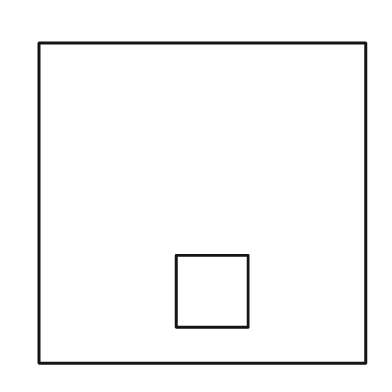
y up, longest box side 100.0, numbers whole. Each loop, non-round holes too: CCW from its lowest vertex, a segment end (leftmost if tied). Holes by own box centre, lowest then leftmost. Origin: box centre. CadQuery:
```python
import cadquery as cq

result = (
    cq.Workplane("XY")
    .moveTo(-50.0, -49.0)
    .lineTo(50.0, -49.0)
    .lineTo(50.0, 49.0)
    .lineTo(-50.0, 49.0)
    .close()
    .moveTo(-8.0, -38.0)
    .lineTo(14.0, -38.0)
    .lineTo(14.0, -16.0)
    .lineTo(-8.0, -16.0)
    .close()
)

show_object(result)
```